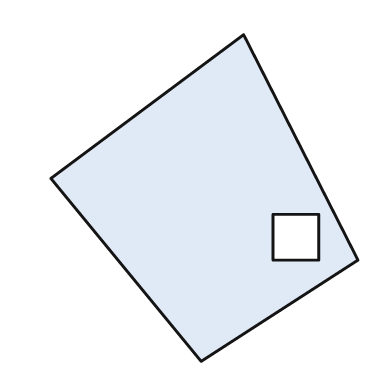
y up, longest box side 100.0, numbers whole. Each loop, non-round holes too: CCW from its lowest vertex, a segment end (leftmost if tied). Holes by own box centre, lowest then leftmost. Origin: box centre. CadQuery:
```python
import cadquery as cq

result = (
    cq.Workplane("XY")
    .moveTo(-1.0, -50.0)
    .lineTo(47.0, -19.0)
    .lineTo(12.0, 50.0)
    .lineTo(-47.0, 6.0)
    .close()
    .moveTo(21.0, -19.0)
    .lineTo(35.0, -19.0)
    .lineTo(35.0, -5.0)
    .lineTo(21.0, -5.0)
    .close()
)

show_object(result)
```